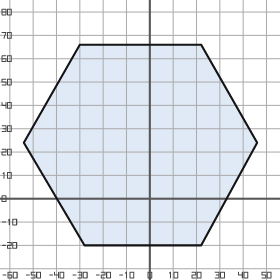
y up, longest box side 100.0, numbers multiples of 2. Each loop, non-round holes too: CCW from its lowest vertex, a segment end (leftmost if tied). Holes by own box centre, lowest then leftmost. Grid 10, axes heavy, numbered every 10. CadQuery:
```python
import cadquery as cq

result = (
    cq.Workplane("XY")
    .moveTo(-28.0, -20.0)
    .lineTo(22.0, -20.0)
    .lineTo(46.0, 24.0)
    .lineTo(22.0, 66.0)
    .lineTo(-30.0, 66.0)
    .lineTo(-54.0, 24.0)
    .close()
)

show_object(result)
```